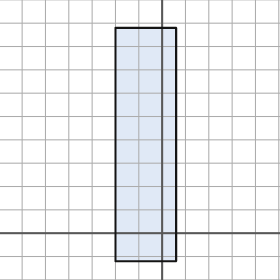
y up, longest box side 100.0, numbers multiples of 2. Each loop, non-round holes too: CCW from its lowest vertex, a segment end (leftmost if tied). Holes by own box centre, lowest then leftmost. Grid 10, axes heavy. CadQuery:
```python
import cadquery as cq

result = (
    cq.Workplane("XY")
    .moveTo(-20.0, -12.0)
    .lineTo(6.0, -12.0)
    .lineTo(6.0, 88.0)
    .lineTo(-20.0, 88.0)
    .close()
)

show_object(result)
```